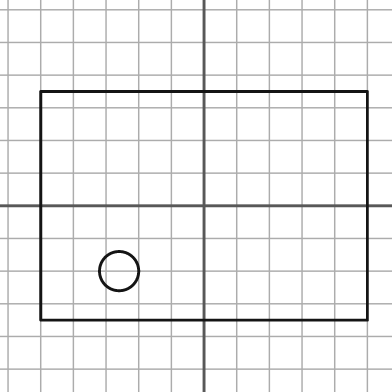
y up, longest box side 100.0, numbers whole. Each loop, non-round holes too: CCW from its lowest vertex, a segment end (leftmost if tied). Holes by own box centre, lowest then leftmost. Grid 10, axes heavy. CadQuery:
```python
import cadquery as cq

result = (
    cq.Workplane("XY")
    .moveTo(-50.0, -35.0)
    .lineTo(50.0, -35.0)
    .lineTo(50.0, 35.0)
    .lineTo(-50.0, 35.0)
    .close()
    .moveTo(-26.0, -20.0)
    .circle(6.0)
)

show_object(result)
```